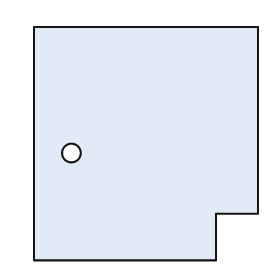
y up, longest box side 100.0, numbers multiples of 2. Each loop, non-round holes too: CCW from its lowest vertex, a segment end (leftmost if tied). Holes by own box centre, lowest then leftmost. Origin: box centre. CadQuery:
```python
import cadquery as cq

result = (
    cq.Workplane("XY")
    .moveTo(-48.0, -50.0)
    .lineTo(30.0, -50.0)
    .lineTo(30.0, -30.0)
    .lineTo(48.0, -30.0)
    .lineTo(48.0, 50.0)
    .lineTo(-48.0, 50.0)
    .close()
    .moveTo(-32.0, -4.0)
    .circle(4.0)
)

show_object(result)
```